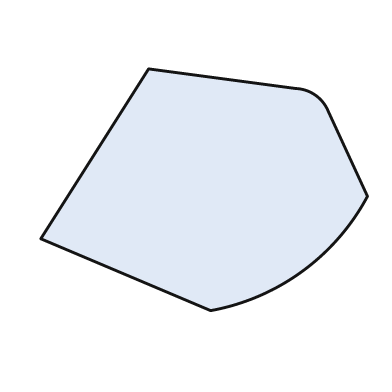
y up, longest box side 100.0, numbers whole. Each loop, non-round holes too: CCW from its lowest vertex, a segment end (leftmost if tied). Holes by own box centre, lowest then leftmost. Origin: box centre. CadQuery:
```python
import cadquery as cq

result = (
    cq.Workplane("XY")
    .moveTo(2.0, -37.0)
    .threePointArc((30.0, -25.0), (50.0, -2.0))
    .lineTo(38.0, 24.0)
    .threePointArc((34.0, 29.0), (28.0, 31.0))
    .lineTo(-17.0, 37.0)
    .lineTo(-50.0, -15.0)
    .close()
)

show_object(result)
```